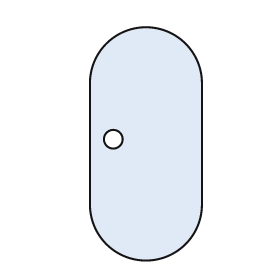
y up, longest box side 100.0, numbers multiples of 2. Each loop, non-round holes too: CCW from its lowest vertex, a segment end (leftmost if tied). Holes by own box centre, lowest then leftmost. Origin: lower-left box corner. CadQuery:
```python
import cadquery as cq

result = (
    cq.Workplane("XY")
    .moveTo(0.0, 24.0)
    .threePointArc((24.0, 0.0), (48.0, 24.0))
    .lineTo(48.0, 76.0)
    .threePointArc((24.0, 100.0), (0.0, 76.0))
    .close()
    .moveTo(10.0, 52.0)
    .circle(4.0)
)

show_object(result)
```